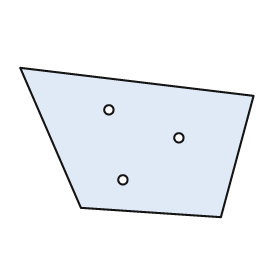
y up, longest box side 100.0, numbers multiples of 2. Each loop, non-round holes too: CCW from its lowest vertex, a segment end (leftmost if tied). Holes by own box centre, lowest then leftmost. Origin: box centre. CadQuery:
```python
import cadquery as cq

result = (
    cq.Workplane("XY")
    .moveTo(36.0, -32.0)
    .lineTo(50.0, 20.0)
    .lineTo(-50.0, 32.0)
    .lineTo(-24.0, -28.0)
    .close()
    .moveTo(-6.0, -16.0)
    .circle(2.0)
    .moveTo(18.0, 2.0)
    .circle(2.0)
    .moveTo(-12.0, 14.0)
    .circle(2.0)
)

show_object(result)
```